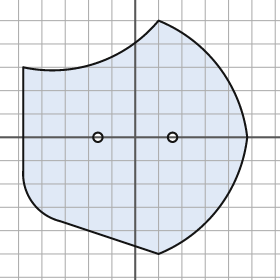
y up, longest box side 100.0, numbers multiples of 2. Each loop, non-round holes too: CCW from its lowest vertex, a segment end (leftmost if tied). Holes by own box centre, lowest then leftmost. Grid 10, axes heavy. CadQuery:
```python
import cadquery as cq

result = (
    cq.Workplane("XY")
    .moveTo(10.0, -50.0)
    .threePointArc((36.0, -30.0), (48.0, 0.0))
    .threePointArc((36.0, 30.0), (10.0, 50.0))
    .threePointArc((-16.0, 32.0), (-48.0, 30.0))
    .lineTo(-48.0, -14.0)
    .threePointArc((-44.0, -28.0), (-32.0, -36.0))
    .close()
    .moveTo(-16.0, 0.0)
    .circle(2.0)
    .moveTo(16.0, 0.0)
    .circle(2.0)
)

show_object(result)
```